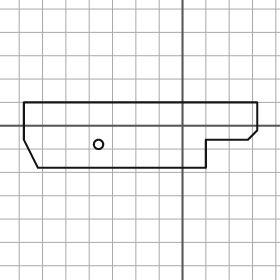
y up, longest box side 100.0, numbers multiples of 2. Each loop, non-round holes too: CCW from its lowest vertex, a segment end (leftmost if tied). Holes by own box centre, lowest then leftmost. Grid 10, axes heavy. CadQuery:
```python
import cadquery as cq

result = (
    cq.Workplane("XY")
    .moveTo(-62.0, -18.0)
    .lineTo(10.0, -18.0)
    .lineTo(10.0, -6.0)
    .lineTo(28.0, -6.0)
    .lineTo(32.0, -2.0)
    .lineTo(32.0, 10.0)
    .lineTo(-68.0, 10.0)
    .lineTo(-68.0, -6.0)
    .close()
    .moveTo(-36.0, -8.0)
    .circle(2.0)
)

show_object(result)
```